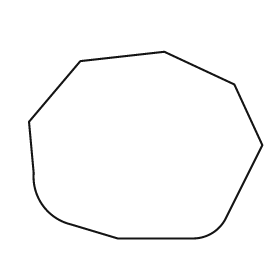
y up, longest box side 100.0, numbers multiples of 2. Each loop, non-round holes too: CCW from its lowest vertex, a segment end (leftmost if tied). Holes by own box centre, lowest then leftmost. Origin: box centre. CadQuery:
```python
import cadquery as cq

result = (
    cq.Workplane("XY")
    .moveTo(-12.0, -40.0)
    .lineTo(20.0, -40.0)
    .threePointArc((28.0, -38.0), (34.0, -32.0))
    .lineTo(50.0, 0.0)
    .lineTo(38.0, 26.0)
    .lineTo(8.0, 40.0)
    .lineTo(-28.0, 36.0)
    .lineTo(-50.0, 10.0)
    .lineTo(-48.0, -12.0)
    .threePointArc((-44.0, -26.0), (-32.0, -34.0))
    .close()
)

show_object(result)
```